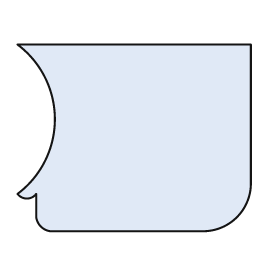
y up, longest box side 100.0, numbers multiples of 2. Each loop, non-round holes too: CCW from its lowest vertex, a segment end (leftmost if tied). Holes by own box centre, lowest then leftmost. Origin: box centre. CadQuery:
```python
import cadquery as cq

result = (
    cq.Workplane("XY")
    .moveTo(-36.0, -40.0)
    .lineTo(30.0, -40.0)
    .threePointArc((44.0, -34.0), (50.0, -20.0))
    .lineTo(50.0, 40.0)
    .lineTo(-50.0, 40.0)
    .threePointArc((-34.0, 8.0), (-50.0, -24.0))
    .threePointArc((-46.0, -26.0), (-42.0, -24.0))
    .lineTo(-42.0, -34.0)
    .threePointArc((-40.0, -38.0), (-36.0, -40.0))
    .close()
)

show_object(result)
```